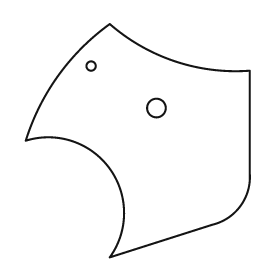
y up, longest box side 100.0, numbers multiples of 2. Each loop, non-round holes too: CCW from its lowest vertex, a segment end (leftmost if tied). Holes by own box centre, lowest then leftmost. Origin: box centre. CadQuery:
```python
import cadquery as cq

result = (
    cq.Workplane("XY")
    .moveTo(-12.0, -50.0)
    .lineTo(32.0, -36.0)
    .threePointArc((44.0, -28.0), (48.0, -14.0))
    .lineTo(48.0, 30.0)
    .threePointArc((16.0, 34.0), (-12.0, 50.0))
    .threePointArc((-34.0, 28.0), (-48.0, 0.0))
    .threePointArc((-12.0, -12.0), (-12.0, -50.0))
    .close()
    .moveTo(8.0, 14.0)
    .circle(4.0)
    .moveTo(-20.0, 32.0)
    .circle(2.0)
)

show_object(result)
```